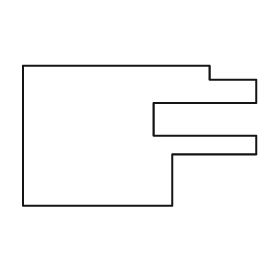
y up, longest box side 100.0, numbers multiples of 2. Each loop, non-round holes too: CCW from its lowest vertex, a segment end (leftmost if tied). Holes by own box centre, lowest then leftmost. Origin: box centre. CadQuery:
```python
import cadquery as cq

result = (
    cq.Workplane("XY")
    .moveTo(-50.0, -30.0)
    .lineTo(14.0, -30.0)
    .lineTo(14.0, -8.0)
    .lineTo(50.0, -8.0)
    .lineTo(50.0, 0.0)
    .lineTo(6.0, 0.0)
    .lineTo(6.0, 14.0)
    .lineTo(50.0, 14.0)
    .lineTo(50.0, 24.0)
    .lineTo(30.0, 24.0)
    .lineTo(30.0, 30.0)
    .lineTo(-50.0, 30.0)
    .close()
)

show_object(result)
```